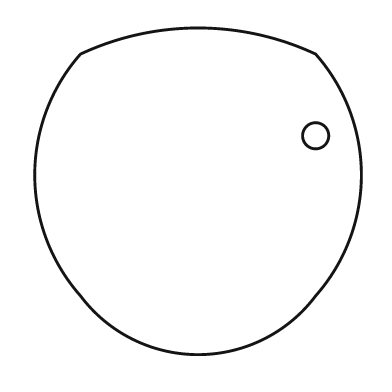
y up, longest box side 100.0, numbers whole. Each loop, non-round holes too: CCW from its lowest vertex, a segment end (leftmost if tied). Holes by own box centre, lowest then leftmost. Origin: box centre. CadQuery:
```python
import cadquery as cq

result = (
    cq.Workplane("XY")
    .moveTo(-36.0, -32.0)
    .threePointArc((0.0, -50.0), (36.0, -32.0))
    .threePointArc((50.0, 5.0), (36.0, 42.0))
    .threePointArc((0.0, 50.0), (-36.0, 42.0))
    .threePointArc((-50.0, 5.0), (-36.0, -32.0))
    .close()
    .moveTo(36.0, 17.0)
    .circle(4.0)
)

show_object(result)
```